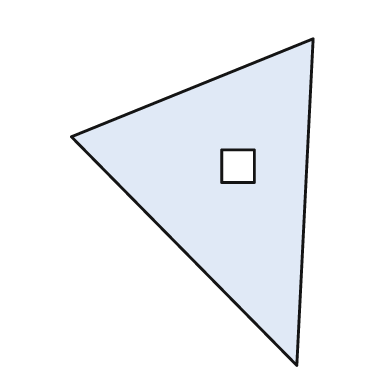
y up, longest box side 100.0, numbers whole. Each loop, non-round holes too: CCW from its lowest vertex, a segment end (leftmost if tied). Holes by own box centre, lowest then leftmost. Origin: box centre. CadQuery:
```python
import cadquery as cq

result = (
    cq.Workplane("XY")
    .moveTo(32.0, -50.0)
    .lineTo(37.0, 50.0)
    .lineTo(-37.0, 20.0)
    .close()
    .moveTo(9.0, 6.0)
    .lineTo(19.0, 6.0)
    .lineTo(19.0, 16.0)
    .lineTo(9.0, 16.0)
    .close()
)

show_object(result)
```